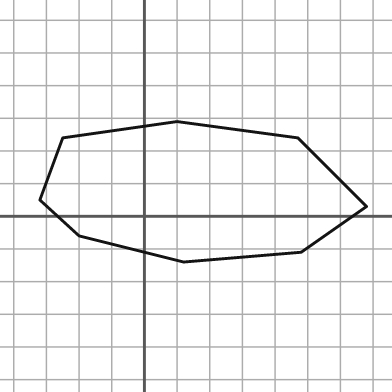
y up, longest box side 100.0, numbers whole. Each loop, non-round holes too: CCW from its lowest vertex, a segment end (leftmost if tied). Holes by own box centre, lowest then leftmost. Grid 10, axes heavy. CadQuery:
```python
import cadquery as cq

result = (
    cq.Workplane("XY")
    .moveTo(12.0, -14.0)
    .lineTo(48.0, -11.0)
    .lineTo(68.0, 3.0)
    .lineTo(47.0, 24.0)
    .lineTo(10.0, 29.0)
    .lineTo(-25.0, 24.0)
    .lineTo(-32.0, 5.0)
    .lineTo(-20.0, -6.0)
    .close()
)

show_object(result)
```